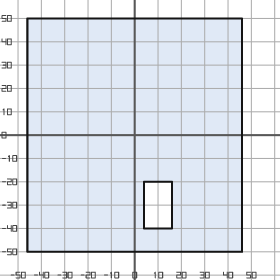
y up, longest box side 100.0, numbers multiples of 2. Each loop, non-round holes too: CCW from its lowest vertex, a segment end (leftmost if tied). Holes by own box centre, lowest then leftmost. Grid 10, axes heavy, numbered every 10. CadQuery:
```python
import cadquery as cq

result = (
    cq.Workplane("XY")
    .moveTo(-46.0, -50.0)
    .lineTo(46.0, -50.0)
    .lineTo(46.0, 50.0)
    .lineTo(-46.0, 50.0)
    .close()
    .moveTo(4.0, -40.0)
    .lineTo(16.0, -40.0)
    .lineTo(16.0, -20.0)
    .lineTo(4.0, -20.0)
    .close()
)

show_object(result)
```